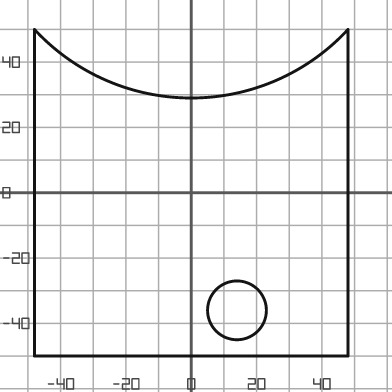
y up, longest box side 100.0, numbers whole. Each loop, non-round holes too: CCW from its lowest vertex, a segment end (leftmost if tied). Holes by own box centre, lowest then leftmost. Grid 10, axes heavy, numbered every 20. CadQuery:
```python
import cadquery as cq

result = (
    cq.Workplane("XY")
    .moveTo(-48.0, -50.0)
    .lineTo(48.0, -50.0)
    .lineTo(48.0, 50.0)
    .threePointArc((0.0, 29.0), (-48.0, 50.0))
    .close()
    .moveTo(14.0, -36.0)
    .circle(9.0)
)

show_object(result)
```